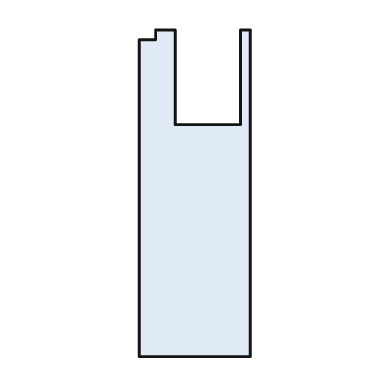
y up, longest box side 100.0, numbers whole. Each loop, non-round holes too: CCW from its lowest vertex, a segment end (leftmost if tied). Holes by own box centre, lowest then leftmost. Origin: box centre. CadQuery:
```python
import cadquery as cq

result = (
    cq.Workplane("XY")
    .moveTo(-17.0, -50.0)
    .lineTo(17.0, -50.0)
    .lineTo(17.0, 50.0)
    .lineTo(14.0, 50.0)
    .lineTo(14.0, 21.0)
    .lineTo(-6.0, 21.0)
    .lineTo(-6.0, 50.0)
    .lineTo(-12.0, 50.0)
    .lineTo(-12.0, 47.0)
    .lineTo(-17.0, 47.0)
    .close()
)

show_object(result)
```